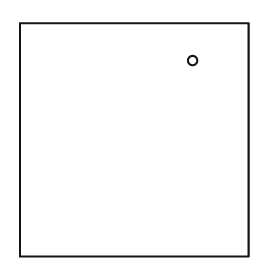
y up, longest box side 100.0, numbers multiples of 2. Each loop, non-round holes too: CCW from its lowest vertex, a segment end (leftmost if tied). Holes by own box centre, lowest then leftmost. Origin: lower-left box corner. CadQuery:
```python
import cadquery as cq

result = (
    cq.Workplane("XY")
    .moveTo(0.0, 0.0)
    .lineTo(98.0, 0.0)
    .lineTo(98.0, 100.0)
    .lineTo(0.0, 100.0)
    .close()
    .moveTo(74.0, 84.0)
    .circle(2.0)
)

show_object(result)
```